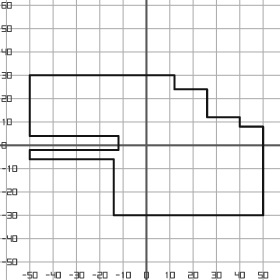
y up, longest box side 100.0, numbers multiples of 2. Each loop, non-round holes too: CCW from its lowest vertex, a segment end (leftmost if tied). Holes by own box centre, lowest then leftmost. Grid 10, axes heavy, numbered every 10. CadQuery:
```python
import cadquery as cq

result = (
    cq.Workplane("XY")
    .moveTo(-14.0, -30.0)
    .lineTo(50.0, -30.0)
    .lineTo(50.0, 8.0)
    .lineTo(40.0, 8.0)
    .lineTo(40.0, 12.0)
    .lineTo(26.0, 12.0)
    .lineTo(26.0, 24.0)
    .lineTo(12.0, 24.0)
    .lineTo(12.0, 30.0)
    .lineTo(-50.0, 30.0)
    .lineTo(-50.0, 4.0)
    .lineTo(-12.0, 4.0)
    .lineTo(-12.0, -2.0)
    .lineTo(-50.0, -2.0)
    .lineTo(-50.0, -6.0)
    .lineTo(-14.0, -6.0)
    .close()
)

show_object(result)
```